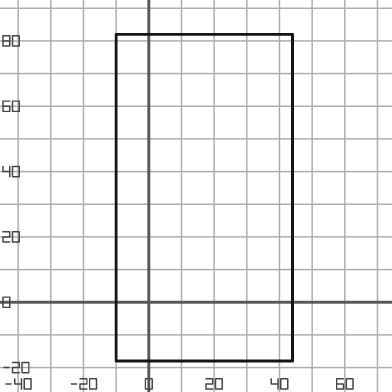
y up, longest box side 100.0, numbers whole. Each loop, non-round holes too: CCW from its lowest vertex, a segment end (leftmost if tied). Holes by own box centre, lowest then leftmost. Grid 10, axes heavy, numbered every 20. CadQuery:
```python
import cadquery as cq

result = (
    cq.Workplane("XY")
    .moveTo(-10.0, -18.0)
    .lineTo(44.0, -18.0)
    .lineTo(44.0, 82.0)
    .lineTo(-10.0, 82.0)
    .close()
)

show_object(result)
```